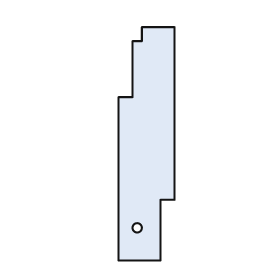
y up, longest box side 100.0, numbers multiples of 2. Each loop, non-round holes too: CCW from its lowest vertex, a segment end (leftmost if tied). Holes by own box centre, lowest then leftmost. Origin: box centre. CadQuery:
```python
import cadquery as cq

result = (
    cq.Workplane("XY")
    .moveTo(-12.0, -50.0)
    .lineTo(6.0, -50.0)
    .lineTo(6.0, -24.0)
    .lineTo(12.0, -24.0)
    .lineTo(12.0, 50.0)
    .lineTo(-2.0, 50.0)
    .lineTo(-2.0, 44.0)
    .lineTo(-6.0, 44.0)
    .lineTo(-6.0, 20.0)
    .lineTo(-12.0, 20.0)
    .close()
    .moveTo(-4.0, -36.0)
    .circle(2.0)
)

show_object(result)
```